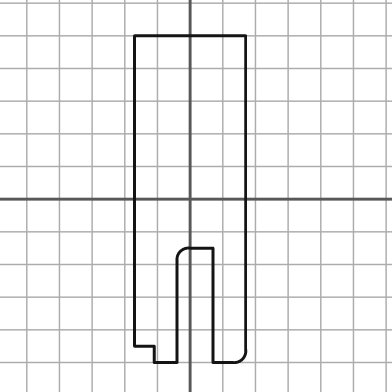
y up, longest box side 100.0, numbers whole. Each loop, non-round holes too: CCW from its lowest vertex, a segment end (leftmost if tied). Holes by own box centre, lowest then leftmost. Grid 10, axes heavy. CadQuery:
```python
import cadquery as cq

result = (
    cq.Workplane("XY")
    .moveTo(-11.0, -50.0)
    .lineTo(-4.0, -50.0)
    .lineTo(-4.0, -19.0)
    .threePointArc((-3.0, -16.0), (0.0, -15.0))
    .lineTo(7.0, -15.0)
    .lineTo(7.0, -50.0)
    .lineTo(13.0, -50.0)
    .threePointArc((16.0, -49.0), (17.0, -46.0))
    .lineTo(17.0, 50.0)
    .lineTo(-17.0, 50.0)
    .lineTo(-17.0, -45.0)
    .lineTo(-11.0, -45.0)
    .close()
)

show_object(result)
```